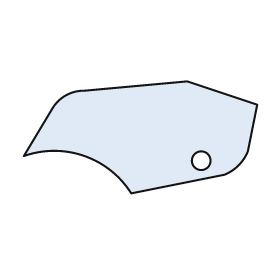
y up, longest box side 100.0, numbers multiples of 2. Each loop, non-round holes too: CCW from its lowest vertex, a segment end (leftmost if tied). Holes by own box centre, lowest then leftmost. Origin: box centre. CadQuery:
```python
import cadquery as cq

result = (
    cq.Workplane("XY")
    .moveTo(-4.0, -24.0)
    .lineTo(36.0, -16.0)
    .threePointArc((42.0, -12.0), (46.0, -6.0))
    .lineTo(50.0, 14.0)
    .lineTo(20.0, 24.0)
    .lineTo(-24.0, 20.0)
    .threePointArc((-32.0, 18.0), (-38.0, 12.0))
    .lineTo(-50.0, -8.0)
    .threePointArc((-24.0, -8.0), (-4.0, -24.0))
    .close()
    .moveTo(26.0, -10.0)
    .circle(4.0)
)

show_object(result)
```